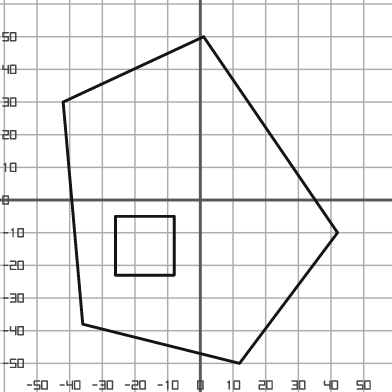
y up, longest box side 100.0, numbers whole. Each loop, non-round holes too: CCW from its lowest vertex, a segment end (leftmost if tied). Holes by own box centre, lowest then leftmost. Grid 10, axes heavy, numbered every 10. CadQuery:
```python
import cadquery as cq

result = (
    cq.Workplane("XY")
    .moveTo(12.0, -50.0)
    .lineTo(42.0, -10.0)
    .lineTo(1.0, 50.0)
    .lineTo(-42.0, 30.0)
    .lineTo(-36.0, -38.0)
    .close()
    .moveTo(-26.0, -23.0)
    .lineTo(-8.0, -23.0)
    .lineTo(-8.0, -5.0)
    .lineTo(-26.0, -5.0)
    .close()
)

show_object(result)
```